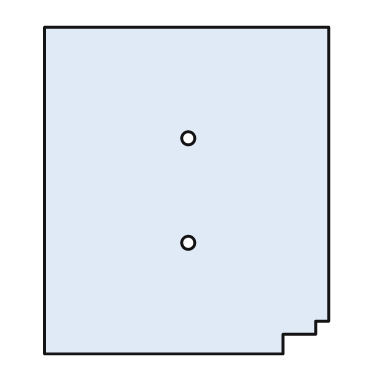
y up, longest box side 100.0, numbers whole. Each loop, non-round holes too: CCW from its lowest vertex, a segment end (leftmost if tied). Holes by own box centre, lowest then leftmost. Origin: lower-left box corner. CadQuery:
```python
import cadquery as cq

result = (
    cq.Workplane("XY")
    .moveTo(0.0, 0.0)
    .lineTo(73.0, 0.0)
    .lineTo(73.0, 6.0)
    .lineTo(83.0, 6.0)
    .lineTo(83.0, 10.0)
    .lineTo(87.0, 10.0)
    .lineTo(87.0, 100.0)
    .lineTo(0.0, 100.0)
    .close()
    .moveTo(44.0, 34.0)
    .circle(2.0)
    .moveTo(44.0, 66.0)
    .circle(2.0)
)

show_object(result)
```